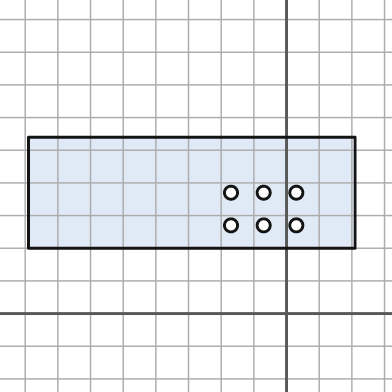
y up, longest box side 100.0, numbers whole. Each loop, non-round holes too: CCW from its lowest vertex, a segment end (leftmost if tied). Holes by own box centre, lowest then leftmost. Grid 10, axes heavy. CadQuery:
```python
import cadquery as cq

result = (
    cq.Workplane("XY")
    .moveTo(-79.0, 20.0)
    .lineTo(21.0, 20.0)
    .lineTo(21.0, 54.0)
    .lineTo(-79.0, 54.0)
    .close()
    .moveTo(-17.0, 27.0)
    .circle(2.0)
    .moveTo(-7.0, 27.0)
    .circle(2.0)
    .moveTo(3.0, 27.0)
    .circle(2.0)
    .moveTo(-17.0, 37.0)
    .circle(2.0)
    .moveTo(-7.0, 37.0)
    .circle(2.0)
    .moveTo(3.0, 37.0)
    .circle(2.0)
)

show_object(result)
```